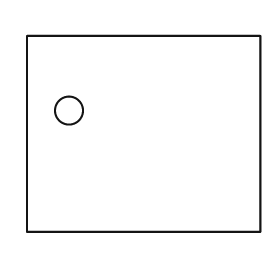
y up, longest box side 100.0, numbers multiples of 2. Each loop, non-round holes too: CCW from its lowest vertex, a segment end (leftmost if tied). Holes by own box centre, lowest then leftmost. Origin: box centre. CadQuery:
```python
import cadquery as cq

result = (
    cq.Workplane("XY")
    .moveTo(-50.0, -42.0)
    .lineTo(50.0, -42.0)
    .lineTo(50.0, 42.0)
    .lineTo(-50.0, 42.0)
    .close()
    .moveTo(-32.0, 10.0)
    .circle(6.0)
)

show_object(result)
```